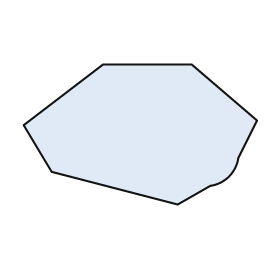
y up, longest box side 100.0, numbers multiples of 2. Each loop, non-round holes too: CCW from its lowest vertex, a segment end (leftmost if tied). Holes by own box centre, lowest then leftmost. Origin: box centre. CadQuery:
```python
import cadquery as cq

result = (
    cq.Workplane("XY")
    .moveTo(16.0, -30.0)
    .lineTo(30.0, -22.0)
    .threePointArc((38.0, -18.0), (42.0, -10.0))
    .lineTo(50.0, 6.0)
    .lineTo(22.0, 30.0)
    .lineTo(-16.0, 30.0)
    .lineTo(-50.0, 4.0)
    .lineTo(-38.0, -16.0)
    .close()
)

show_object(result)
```